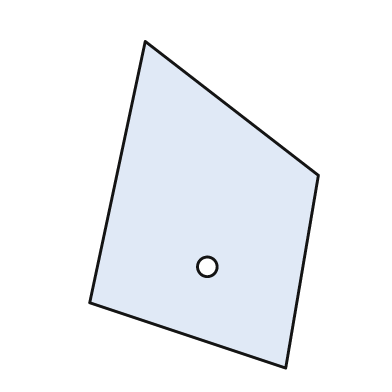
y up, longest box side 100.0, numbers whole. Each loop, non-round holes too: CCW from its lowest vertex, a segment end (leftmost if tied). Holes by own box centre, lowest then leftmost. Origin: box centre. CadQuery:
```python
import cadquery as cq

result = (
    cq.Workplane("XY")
    .moveTo(25.0, -50.0)
    .lineTo(35.0, 9.0)
    .lineTo(-18.0, 50.0)
    .lineTo(-35.0, -30.0)
    .close()
    .moveTo(1.0, -19.0)
    .circle(3.0)
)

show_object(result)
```